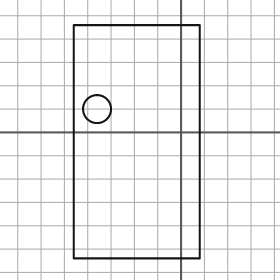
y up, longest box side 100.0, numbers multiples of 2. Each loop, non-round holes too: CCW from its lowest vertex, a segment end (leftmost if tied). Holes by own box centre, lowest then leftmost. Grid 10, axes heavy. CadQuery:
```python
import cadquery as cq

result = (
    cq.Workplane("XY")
    .moveTo(-46.0, -54.0)
    .lineTo(8.0, -54.0)
    .lineTo(8.0, 46.0)
    .lineTo(-46.0, 46.0)
    .close()
    .moveTo(-36.0, 10.0)
    .circle(6.0)
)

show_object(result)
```